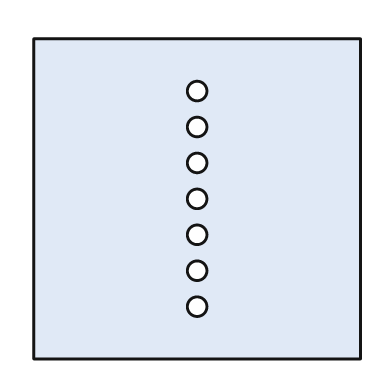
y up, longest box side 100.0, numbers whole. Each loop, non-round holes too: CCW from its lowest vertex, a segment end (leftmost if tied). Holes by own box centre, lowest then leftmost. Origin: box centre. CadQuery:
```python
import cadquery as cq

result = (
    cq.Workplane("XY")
    .moveTo(-50.0, -49.0)
    .lineTo(50.0, -49.0)
    .lineTo(50.0, 49.0)
    .lineTo(-50.0, 49.0)
    .close()
    .moveTo(0.0, -33.0)
    .circle(3.0)
    .moveTo(0.0, -22.0)
    .circle(3.0)
    .moveTo(0.0, -11.0)
    .circle(3.0)
    .moveTo(0.0, 0.0)
    .circle(3.0)
    .moveTo(0.0, 11.0)
    .circle(3.0)
    .moveTo(0.0, 22.0)
    .circle(3.0)
    .moveTo(0.0, 33.0)
    .circle(3.0)
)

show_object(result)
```